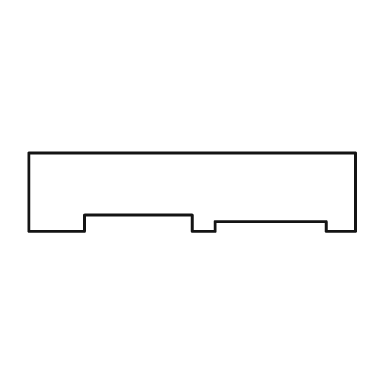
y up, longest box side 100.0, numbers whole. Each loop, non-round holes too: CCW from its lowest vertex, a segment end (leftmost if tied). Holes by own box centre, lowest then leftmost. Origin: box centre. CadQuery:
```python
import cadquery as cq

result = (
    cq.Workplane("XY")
    .moveTo(-50.0, -12.0)
    .lineTo(-33.0, -12.0)
    .lineTo(-33.0, -7.0)
    .lineTo(0.0, -7.0)
    .lineTo(0.0, -12.0)
    .lineTo(7.0, -12.0)
    .lineTo(7.0, -9.0)
    .lineTo(41.0, -9.0)
    .lineTo(41.0, -12.0)
    .lineTo(50.0, -12.0)
    .lineTo(50.0, 12.0)
    .lineTo(-50.0, 12.0)
    .close()
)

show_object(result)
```